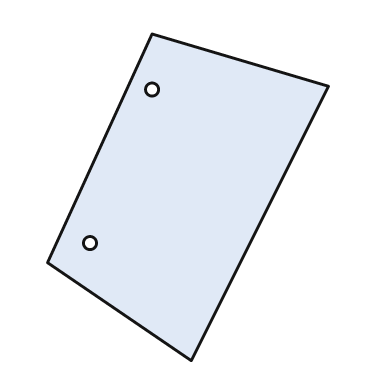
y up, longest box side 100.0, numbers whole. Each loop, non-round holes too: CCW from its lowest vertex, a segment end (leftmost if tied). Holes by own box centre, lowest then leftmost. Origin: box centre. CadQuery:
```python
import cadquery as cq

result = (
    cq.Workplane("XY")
    .moveTo(1.0, -50.0)
    .lineTo(43.0, 34.0)
    .lineTo(-11.0, 50.0)
    .lineTo(-43.0, -20.0)
    .close()
    .moveTo(-30.0, -14.0)
    .circle(2.0)
    .moveTo(-11.0, 33.0)
    .circle(2.0)
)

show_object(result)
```